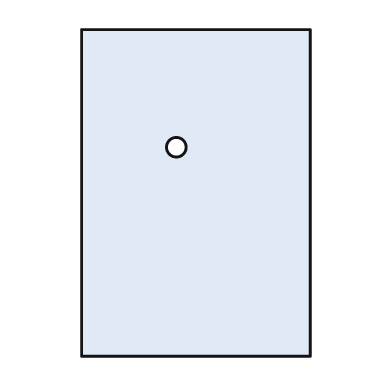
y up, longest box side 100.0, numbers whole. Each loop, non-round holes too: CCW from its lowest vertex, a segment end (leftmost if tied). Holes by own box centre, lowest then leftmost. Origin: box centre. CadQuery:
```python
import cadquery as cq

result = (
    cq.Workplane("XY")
    .moveTo(-35.0, -50.0)
    .lineTo(35.0, -50.0)
    .lineTo(35.0, 50.0)
    .lineTo(-35.0, 50.0)
    .close()
    .moveTo(-6.0, 14.0)
    .circle(3.0)
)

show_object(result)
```